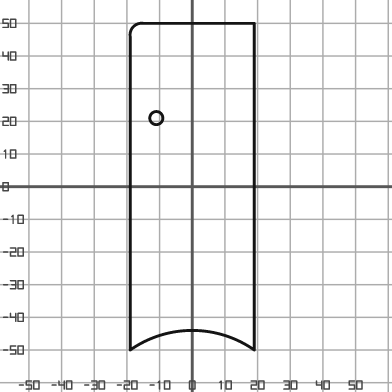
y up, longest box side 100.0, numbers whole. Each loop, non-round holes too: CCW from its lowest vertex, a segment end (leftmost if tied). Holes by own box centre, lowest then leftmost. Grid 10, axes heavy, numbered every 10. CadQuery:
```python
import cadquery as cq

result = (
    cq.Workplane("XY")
    .moveTo(-19.0, -50.0)
    .threePointArc((0.0, -44.0), (19.0, -50.0))
    .lineTo(19.0, 50.0)
    .lineTo(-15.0, 50.0)
    .threePointArc((-18.0, 49.0), (-19.0, 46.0))
    .close()
    .moveTo(-11.0, 21.0)
    .circle(2.0)
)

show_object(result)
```